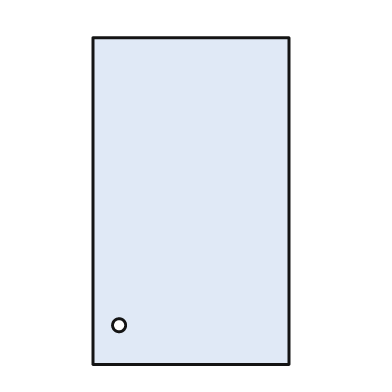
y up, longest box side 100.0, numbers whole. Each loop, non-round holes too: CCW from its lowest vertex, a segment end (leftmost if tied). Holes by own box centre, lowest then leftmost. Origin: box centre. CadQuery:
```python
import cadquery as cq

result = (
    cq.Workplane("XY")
    .moveTo(-30.0, -50.0)
    .lineTo(30.0, -50.0)
    .lineTo(30.0, 50.0)
    .lineTo(-30.0, 50.0)
    .close()
    .moveTo(-22.0, -38.0)
    .circle(2.0)
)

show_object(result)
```